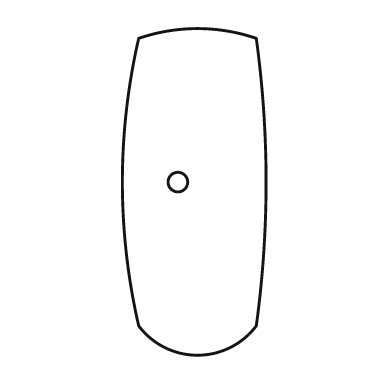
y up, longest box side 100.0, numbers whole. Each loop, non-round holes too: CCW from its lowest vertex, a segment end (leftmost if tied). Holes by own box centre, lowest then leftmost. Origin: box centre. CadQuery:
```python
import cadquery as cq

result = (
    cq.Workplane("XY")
    .moveTo(-17.0, -41.0)
    .threePointArc((1.0, -50.0), (19.0, -41.0))
    .threePointArc((22.0, 3.0), (19.0, 47.0))
    .threePointArc((1.0, 50.0), (-17.0, 47.0))
    .threePointArc((-22.0, 3.0), (-17.0, -41.0))
    .close()
    .moveTo(-5.0, 3.0)
    .circle(3.0)
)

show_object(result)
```